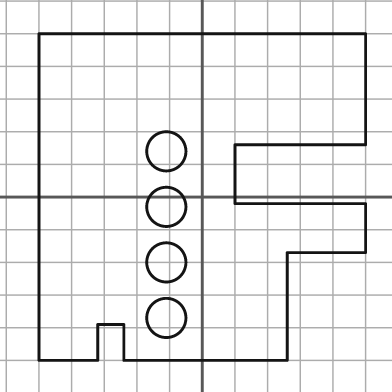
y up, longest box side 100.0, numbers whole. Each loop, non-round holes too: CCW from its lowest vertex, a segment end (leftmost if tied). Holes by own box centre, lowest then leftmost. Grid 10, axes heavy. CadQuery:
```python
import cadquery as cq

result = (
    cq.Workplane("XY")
    .moveTo(-50.0, -50.0)
    .lineTo(-32.0, -50.0)
    .lineTo(-32.0, -39.0)
    .lineTo(-24.0, -39.0)
    .lineTo(-24.0, -50.0)
    .lineTo(26.0, -50.0)
    .lineTo(26.0, -17.0)
    .lineTo(50.0, -17.0)
    .lineTo(50.0, -2.0)
    .lineTo(10.0, -2.0)
    .lineTo(10.0, 16.0)
    .lineTo(50.0, 16.0)
    .lineTo(50.0, 50.0)
    .lineTo(-50.0, 50.0)
    .close()
    .moveTo(-11.0, -37.0)
    .circle(6.0)
    .moveTo(-11.0, -20.0)
    .circle(6.0)
    .moveTo(-11.0, -3.0)
    .circle(6.0)
    .moveTo(-11.0, 14.0)
    .circle(6.0)
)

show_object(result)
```